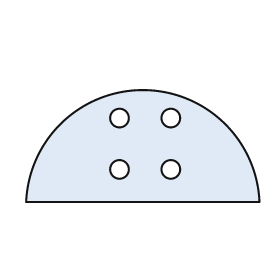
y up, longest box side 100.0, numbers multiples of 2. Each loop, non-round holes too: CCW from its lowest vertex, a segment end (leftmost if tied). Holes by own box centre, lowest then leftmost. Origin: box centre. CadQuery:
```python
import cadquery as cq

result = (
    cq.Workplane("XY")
    .moveTo(-50.0, -24.0)
    .lineTo(50.0, -24.0)
    .threePointArc((0.0, 24.0), (-50.0, -24.0))
    .close()
    .moveTo(-10.0, -10.0)
    .circle(4.0)
    .moveTo(12.0, -10.0)
    .circle(4.0)
    .moveTo(-10.0, 12.0)
    .circle(4.0)
    .moveTo(12.0, 12.0)
    .circle(4.0)
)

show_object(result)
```